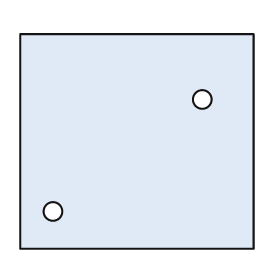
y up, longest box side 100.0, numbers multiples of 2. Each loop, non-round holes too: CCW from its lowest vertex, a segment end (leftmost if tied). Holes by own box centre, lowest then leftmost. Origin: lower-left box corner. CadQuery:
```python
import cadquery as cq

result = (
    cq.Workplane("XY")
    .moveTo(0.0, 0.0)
    .lineTo(100.0, 0.0)
    .lineTo(100.0, 92.0)
    .lineTo(0.0, 92.0)
    .close()
    .moveTo(14.0, 16.0)
    .circle(4.0)
    .moveTo(78.0, 64.0)
    .circle(4.0)
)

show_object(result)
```